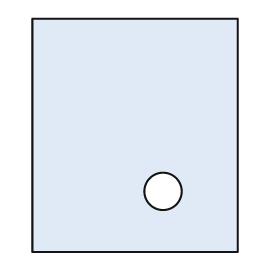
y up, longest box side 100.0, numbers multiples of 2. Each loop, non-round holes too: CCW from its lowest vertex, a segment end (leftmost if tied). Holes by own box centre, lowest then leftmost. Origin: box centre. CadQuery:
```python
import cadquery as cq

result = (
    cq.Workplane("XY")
    .moveTo(-44.0, -50.0)
    .lineTo(44.0, -50.0)
    .lineTo(44.0, 50.0)
    .lineTo(-44.0, 50.0)
    .close()
    .moveTo(12.0, -24.0)
    .circle(8.0)
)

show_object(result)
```